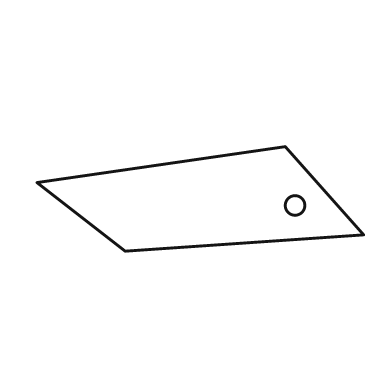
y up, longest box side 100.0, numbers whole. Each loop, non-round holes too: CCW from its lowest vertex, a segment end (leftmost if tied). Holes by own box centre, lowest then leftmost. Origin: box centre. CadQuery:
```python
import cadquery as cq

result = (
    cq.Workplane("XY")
    .moveTo(-23.0, -16.0)
    .lineTo(50.0, -11.0)
    .lineTo(26.0, 16.0)
    .lineTo(-50.0, 5.0)
    .close()
    .moveTo(29.0, -2.0)
    .circle(3.0)
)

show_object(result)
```